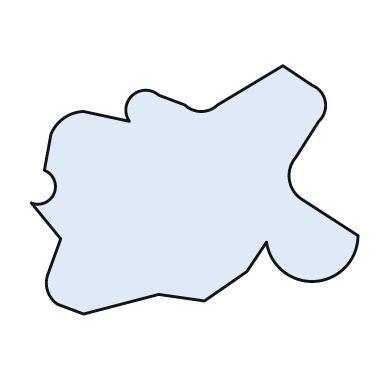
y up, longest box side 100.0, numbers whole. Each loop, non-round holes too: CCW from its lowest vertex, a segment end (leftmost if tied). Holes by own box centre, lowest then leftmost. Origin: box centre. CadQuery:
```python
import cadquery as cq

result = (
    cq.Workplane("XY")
    .moveTo(-34.0, -38.0)
    .lineTo(-11.0, -32.0)
    .lineTo(3.0, -34.0)
    .lineTo(16.0, -25.0)
    .lineTo(22.0, -16.0)
    .threePointArc((37.0, -28.0), (50.0, -14.0))
    .lineTo(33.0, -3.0)
    .threePointArc((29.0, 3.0), (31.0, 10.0))
    .lineTo(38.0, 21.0)
    .threePointArc((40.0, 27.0), (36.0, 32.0))
    .lineTo(27.0, 38.0)
    .lineTo(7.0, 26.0)
    .threePointArc((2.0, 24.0), (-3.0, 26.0))
    .lineTo(-11.0, 29.0)
    .threePointArc((-19.0, 29.0), (-20.0, 21.0))
    .lineTo(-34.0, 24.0)
    .threePointArc((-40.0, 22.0), (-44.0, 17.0))
    .lineTo(-46.0, 6.0)
    .threePointArc((-43.0, -1.0), (-50.0, -4.0))
    .lineTo(-41.0, -15.0)
    .lineTo(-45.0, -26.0)
    .threePointArc((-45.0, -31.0), (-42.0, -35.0))
    .close()
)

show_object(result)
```